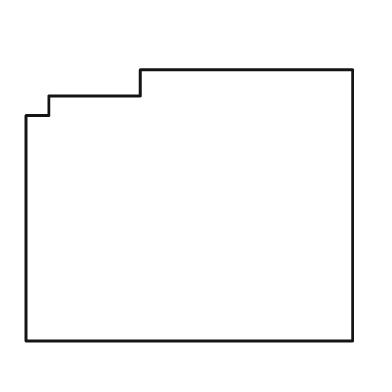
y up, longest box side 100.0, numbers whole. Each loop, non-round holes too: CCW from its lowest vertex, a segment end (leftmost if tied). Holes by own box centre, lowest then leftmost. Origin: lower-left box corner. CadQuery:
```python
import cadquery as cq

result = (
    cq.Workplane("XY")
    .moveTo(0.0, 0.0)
    .lineTo(100.0, 0.0)
    .lineTo(100.0, 83.0)
    .lineTo(35.0, 83.0)
    .lineTo(35.0, 75.0)
    .lineTo(7.0, 75.0)
    .lineTo(7.0, 69.0)
    .lineTo(0.0, 69.0)
    .close()
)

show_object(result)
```